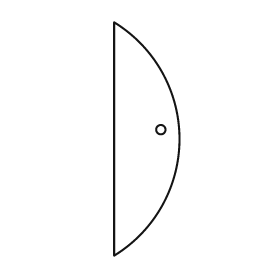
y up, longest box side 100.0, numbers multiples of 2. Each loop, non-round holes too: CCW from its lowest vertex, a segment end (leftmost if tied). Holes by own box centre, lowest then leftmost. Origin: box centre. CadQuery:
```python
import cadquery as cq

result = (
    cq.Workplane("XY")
    .moveTo(-14.0, -50.0)
    .threePointArc((14.0, 0.0), (-14.0, 50.0))
    .close()
    .moveTo(6.0, 4.0)
    .circle(2.0)
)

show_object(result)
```